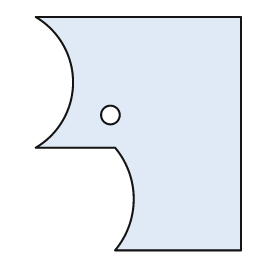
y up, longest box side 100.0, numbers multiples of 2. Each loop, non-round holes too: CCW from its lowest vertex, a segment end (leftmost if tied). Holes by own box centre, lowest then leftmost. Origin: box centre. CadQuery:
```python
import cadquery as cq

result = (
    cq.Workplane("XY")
    .moveTo(-10.0, -50.0)
    .lineTo(44.0, -50.0)
    .lineTo(44.0, 50.0)
    .lineTo(-44.0, 50.0)
    .threePointArc((-28.0, 22.0), (-44.0, -6.0))
    .lineTo(-10.0, -6.0)
    .threePointArc((-2.0, -28.0), (-10.0, -50.0))
    .close()
    .moveTo(-12.0, 8.0)
    .circle(4.0)
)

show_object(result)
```